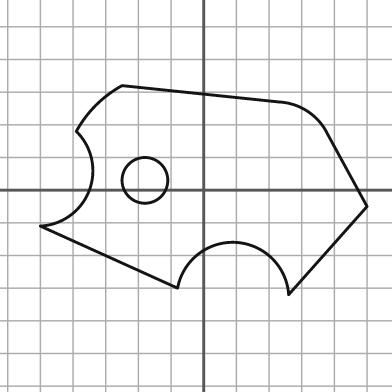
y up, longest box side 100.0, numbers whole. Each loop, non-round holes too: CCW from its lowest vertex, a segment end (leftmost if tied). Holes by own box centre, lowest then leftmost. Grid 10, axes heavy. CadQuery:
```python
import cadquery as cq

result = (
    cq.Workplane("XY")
    .moveTo(26.0, -32.0)
    .lineTo(50.0, -5.0)
    .lineTo(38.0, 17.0)
    .threePointArc((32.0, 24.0), (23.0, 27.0))
    .lineTo(-25.0, 32.0)
    .threePointArc((-33.0, 26.0), (-39.0, 18.0))
    .threePointArc((-35.0, 0.0), (-50.0, -11.0))
    .lineTo(-8.0, -30.0)
    .threePointArc((10.0, -16.0), (26.0, -32.0))
    .close()
    .moveTo(-18.0, 3.0)
    .circle(7.0)
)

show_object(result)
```